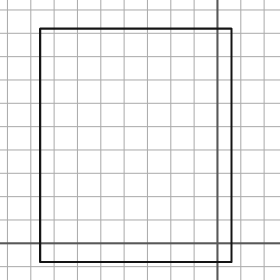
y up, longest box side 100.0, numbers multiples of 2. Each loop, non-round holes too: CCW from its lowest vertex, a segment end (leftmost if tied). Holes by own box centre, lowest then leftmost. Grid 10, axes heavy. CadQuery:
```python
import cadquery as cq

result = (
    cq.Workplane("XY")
    .moveTo(-76.0, -8.0)
    .lineTo(6.0, -8.0)
    .lineTo(6.0, 92.0)
    .lineTo(-76.0, 92.0)
    .close()
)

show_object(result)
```